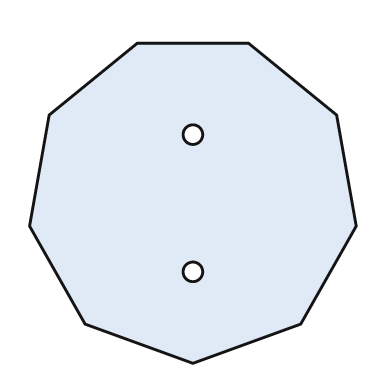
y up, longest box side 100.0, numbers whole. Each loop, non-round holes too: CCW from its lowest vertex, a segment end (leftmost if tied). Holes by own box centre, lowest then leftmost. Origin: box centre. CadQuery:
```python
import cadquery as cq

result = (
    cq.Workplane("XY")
    .moveTo(0.0, -49.0)
    .lineTo(33.0, -37.0)
    .lineTo(50.0, -7.0)
    .lineTo(44.0, 27.0)
    .lineTo(17.0, 49.0)
    .lineTo(-17.0, 49.0)
    .lineTo(-44.0, 27.0)
    .lineTo(-50.0, -7.0)
    .lineTo(-33.0, -37.0)
    .close()
    .moveTo(0.0, -21.0)
    .circle(3.0)
    .moveTo(0.0, 21.0)
    .circle(3.0)
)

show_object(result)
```